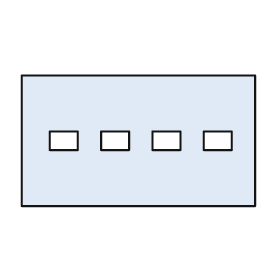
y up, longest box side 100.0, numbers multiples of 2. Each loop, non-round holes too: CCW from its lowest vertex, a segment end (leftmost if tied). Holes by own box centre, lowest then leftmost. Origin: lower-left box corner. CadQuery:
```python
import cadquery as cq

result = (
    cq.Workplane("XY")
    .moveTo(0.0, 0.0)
    .lineTo(100.0, 0.0)
    .lineTo(100.0, 56.0)
    .lineTo(0.0, 56.0)
    .close()
    .moveTo(12.0, 24.0)
    .lineTo(24.0, 24.0)
    .lineTo(24.0, 32.0)
    .lineTo(12.0, 32.0)
    .close()
    .moveTo(34.0, 24.0)
    .lineTo(46.0, 24.0)
    .lineTo(46.0, 32.0)
    .lineTo(34.0, 32.0)
    .close()
    .moveTo(56.0, 24.0)
    .lineTo(68.0, 24.0)
    .lineTo(68.0, 32.0)
    .lineTo(56.0, 32.0)
    .close()
    .moveTo(78.0, 24.0)
    .lineTo(90.0, 24.0)
    .lineTo(90.0, 32.0)
    .lineTo(78.0, 32.0)
    .close()
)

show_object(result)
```